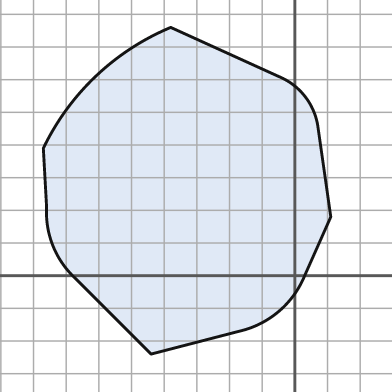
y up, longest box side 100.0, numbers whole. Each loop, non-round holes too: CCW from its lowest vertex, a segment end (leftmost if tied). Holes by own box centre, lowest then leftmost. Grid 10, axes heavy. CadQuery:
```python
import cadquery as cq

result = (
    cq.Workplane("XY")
    .moveTo(-44.0, -24.0)
    .lineTo(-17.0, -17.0)
    .threePointArc((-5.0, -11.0), (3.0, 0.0))
    .lineTo(11.0, 18.0)
    .lineTo(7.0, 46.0)
    .threePointArc((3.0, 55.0), (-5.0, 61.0))
    .lineTo(-38.0, 76.0)
    .threePointArc((-61.0, 61.0), (-77.0, 39.0))
    .lineTo(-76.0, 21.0)
    .threePointArc((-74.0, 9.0), (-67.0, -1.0))
    .close()
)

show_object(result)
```